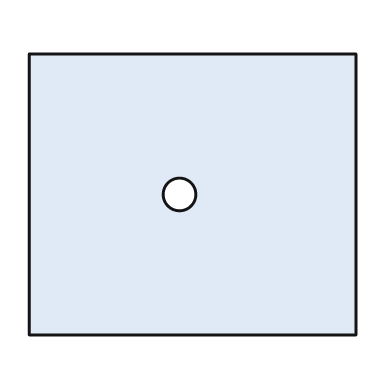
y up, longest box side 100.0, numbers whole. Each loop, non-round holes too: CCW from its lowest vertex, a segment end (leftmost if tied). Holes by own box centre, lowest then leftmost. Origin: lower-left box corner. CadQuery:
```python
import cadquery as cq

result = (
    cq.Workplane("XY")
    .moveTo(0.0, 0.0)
    .lineTo(100.0, 0.0)
    .lineTo(100.0, 86.0)
    .lineTo(0.0, 86.0)
    .close()
    .moveTo(46.0, 43.0)
    .circle(5.0)
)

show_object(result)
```